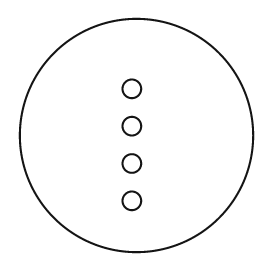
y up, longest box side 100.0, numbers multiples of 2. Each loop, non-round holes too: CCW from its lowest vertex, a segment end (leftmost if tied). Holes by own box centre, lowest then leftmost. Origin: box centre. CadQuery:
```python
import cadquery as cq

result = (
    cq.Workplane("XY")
    .moveTo(0.0, 0.0)
    .circle(50.0)
    .moveTo(-2.0, -28.0)
    .circle(4.0)
    .moveTo(-2.0, -12.0)
    .circle(4.0)
    .moveTo(-2.0, 4.0)
    .circle(4.0)
    .moveTo(-2.0, 20.0)
    .circle(4.0)
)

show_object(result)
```